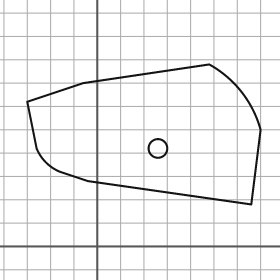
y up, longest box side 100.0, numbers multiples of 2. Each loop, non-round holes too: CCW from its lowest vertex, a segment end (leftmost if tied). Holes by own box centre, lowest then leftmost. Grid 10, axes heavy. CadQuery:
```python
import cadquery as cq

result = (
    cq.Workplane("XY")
    .moveTo(66.0, 18.0)
    .lineTo(70.0, 50.0)
    .threePointArc((62.0, 66.0), (48.0, 78.0))
    .lineTo(-6.0, 70.0)
    .lineTo(-30.0, 62.0)
    .lineTo(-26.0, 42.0)
    .threePointArc((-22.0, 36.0), (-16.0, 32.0))
    .lineTo(-4.0, 28.0)
    .close()
    .moveTo(26.0, 42.0)
    .circle(4.0)
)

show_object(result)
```